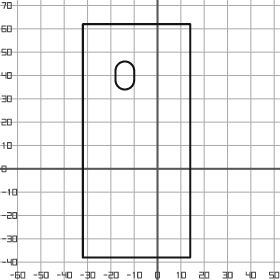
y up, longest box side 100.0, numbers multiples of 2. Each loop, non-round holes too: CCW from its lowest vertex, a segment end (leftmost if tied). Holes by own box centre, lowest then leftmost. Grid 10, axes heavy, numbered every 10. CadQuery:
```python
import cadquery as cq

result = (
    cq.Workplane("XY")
    .moveTo(-32.0, -38.0)
    .lineTo(14.0, -38.0)
    .lineTo(14.0, 62.0)
    .lineTo(-32.0, 62.0)
    .close()
    .moveTo(-18.0, 38.0)
    .threePointArc((-14.0, 34.0), (-10.0, 38.0))
    .lineTo(-10.0, 42.0)
    .threePointArc((-14.0, 46.0), (-18.0, 42.0))
    .close()
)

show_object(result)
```